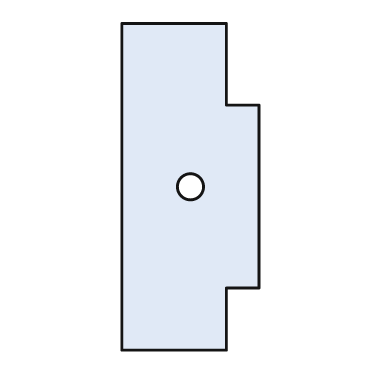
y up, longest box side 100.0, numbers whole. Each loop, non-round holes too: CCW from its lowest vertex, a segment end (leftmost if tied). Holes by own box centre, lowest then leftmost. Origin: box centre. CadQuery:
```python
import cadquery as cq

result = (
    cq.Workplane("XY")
    .moveTo(-21.0, -50.0)
    .lineTo(11.0, -50.0)
    .lineTo(11.0, -31.0)
    .lineTo(21.0, -31.0)
    .lineTo(21.0, 25.0)
    .lineTo(11.0, 25.0)
    .lineTo(11.0, 50.0)
    .lineTo(-21.0, 50.0)
    .close()
    .moveTo(0.0, 0.0)
    .circle(4.0)
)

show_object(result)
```